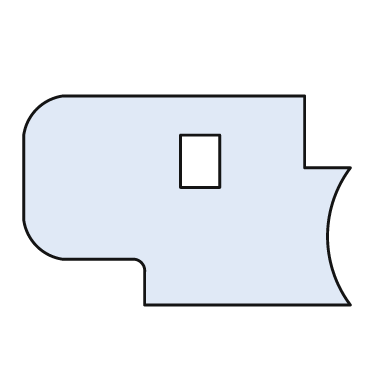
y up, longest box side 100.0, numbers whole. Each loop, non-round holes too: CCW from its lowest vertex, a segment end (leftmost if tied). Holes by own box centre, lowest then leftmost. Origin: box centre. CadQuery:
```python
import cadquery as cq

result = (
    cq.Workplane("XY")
    .moveTo(-13.0, -32.0)
    .lineTo(50.0, -32.0)
    .threePointArc((43.0, -11.0), (50.0, 10.0))
    .lineTo(36.0, 10.0)
    .lineTo(36.0, 32.0)
    .lineTo(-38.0, 32.0)
    .threePointArc((-46.0, 28.0), (-50.0, 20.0))
    .lineTo(-50.0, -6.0)
    .threePointArc((-46.0, -14.0), (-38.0, -18.0))
    .lineTo(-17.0, -18.0)
    .threePointArc((-14.0, -19.0), (-13.0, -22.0))
    .close()
    .moveTo(-2.0, 4.0)
    .lineTo(10.0, 4.0)
    .lineTo(10.0, 20.0)
    .lineTo(-2.0, 20.0)
    .close()
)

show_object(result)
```